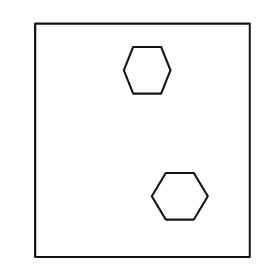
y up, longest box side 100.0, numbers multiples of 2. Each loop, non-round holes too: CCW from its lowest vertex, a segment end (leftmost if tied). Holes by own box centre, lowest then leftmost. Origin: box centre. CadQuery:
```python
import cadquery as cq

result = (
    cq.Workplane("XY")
    .moveTo(-46.0, -50.0)
    .lineTo(46.0, -50.0)
    .lineTo(46.0, 50.0)
    .lineTo(-46.0, 50.0)
    .close()
    .moveTo(10.0, -34.0)
    .lineTo(22.0, -34.0)
    .lineTo(28.0, -24.0)
    .lineTo(22.0, -14.0)
    .lineTo(10.0, -14.0)
    .lineTo(4.0, -24.0)
    .close()
    .moveTo(-4.0, 20.0)
    .lineTo(8.0, 20.0)
    .lineTo(12.0, 30.0)
    .lineTo(8.0, 40.0)
    .lineTo(-4.0, 40.0)
    .lineTo(-8.0, 30.0)
    .close()
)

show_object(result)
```